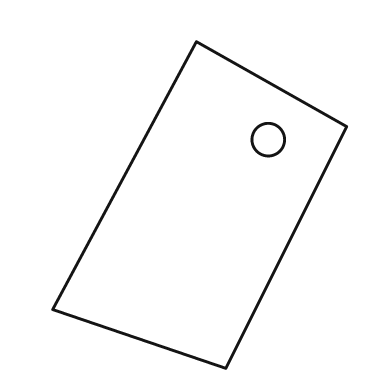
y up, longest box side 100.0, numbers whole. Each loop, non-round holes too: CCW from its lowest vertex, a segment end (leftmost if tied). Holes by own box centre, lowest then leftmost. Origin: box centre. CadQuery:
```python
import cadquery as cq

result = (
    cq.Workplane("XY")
    .moveTo(8.0, -50.0)
    .lineTo(45.0, 24.0)
    .lineTo(-1.0, 50.0)
    .lineTo(-45.0, -32.0)
    .close()
    .moveTo(21.0, 20.0)
    .circle(5.0)
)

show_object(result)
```